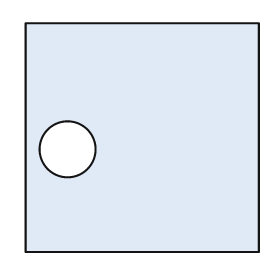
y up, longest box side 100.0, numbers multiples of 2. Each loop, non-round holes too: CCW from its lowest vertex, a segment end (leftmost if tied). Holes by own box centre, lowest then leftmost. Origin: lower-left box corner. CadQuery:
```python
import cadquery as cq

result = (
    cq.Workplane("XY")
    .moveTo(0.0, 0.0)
    .lineTo(100.0, 0.0)
    .lineTo(100.0, 98.0)
    .lineTo(0.0, 98.0)
    .close()
    .moveTo(18.0, 44.0)
    .circle(12.0)
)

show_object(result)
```